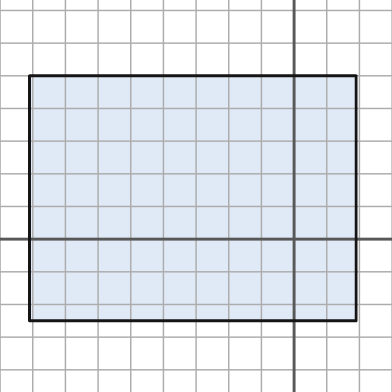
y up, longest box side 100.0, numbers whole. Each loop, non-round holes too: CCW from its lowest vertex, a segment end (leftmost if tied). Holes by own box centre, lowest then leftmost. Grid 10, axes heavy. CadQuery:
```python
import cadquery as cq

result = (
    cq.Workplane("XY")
    .moveTo(-81.0, -25.0)
    .lineTo(19.0, -25.0)
    .lineTo(19.0, 50.0)
    .lineTo(-81.0, 50.0)
    .close()
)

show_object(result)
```